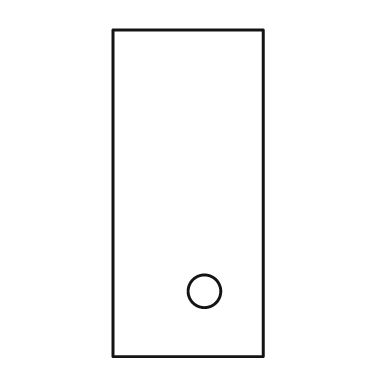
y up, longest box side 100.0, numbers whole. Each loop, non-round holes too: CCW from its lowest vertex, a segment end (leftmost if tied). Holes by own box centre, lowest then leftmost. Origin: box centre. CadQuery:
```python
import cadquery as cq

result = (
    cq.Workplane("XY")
    .moveTo(-23.0, -50.0)
    .lineTo(23.0, -50.0)
    .lineTo(23.0, 50.0)
    .lineTo(-23.0, 50.0)
    .close()
    .moveTo(5.0, -30.0)
    .circle(5.0)
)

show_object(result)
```